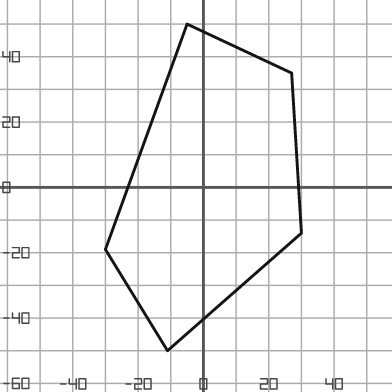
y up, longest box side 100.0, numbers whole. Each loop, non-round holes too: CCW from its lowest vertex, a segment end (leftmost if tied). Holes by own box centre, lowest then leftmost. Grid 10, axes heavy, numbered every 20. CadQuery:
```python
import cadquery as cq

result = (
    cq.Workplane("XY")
    .moveTo(-11.0, -50.0)
    .lineTo(30.0, -14.0)
    .lineTo(27.0, 35.0)
    .lineTo(-5.0, 50.0)
    .lineTo(-30.0, -19.0)
    .close()
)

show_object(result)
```